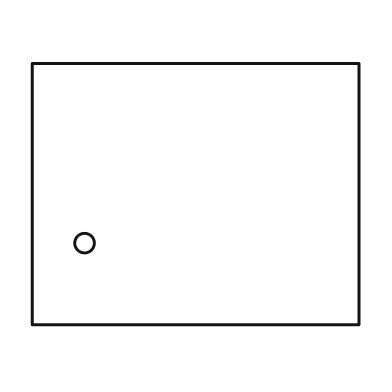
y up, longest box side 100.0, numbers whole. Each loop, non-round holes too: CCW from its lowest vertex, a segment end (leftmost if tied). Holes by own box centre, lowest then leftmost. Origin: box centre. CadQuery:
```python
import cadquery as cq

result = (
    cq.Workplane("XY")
    .moveTo(-50.0, -40.0)
    .lineTo(50.0, -40.0)
    .lineTo(50.0, 40.0)
    .lineTo(-50.0, 40.0)
    .close()
    .moveTo(-34.0, -15.0)
    .circle(3.0)
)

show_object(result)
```